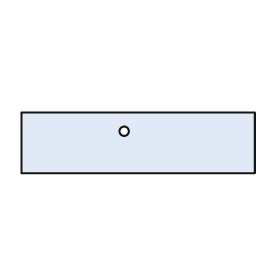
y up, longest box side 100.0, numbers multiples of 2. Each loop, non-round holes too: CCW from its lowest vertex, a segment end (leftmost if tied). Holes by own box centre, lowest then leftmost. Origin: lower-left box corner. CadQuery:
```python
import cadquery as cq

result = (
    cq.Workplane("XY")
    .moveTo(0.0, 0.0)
    .lineTo(100.0, 0.0)
    .lineTo(100.0, 26.0)
    .lineTo(0.0, 26.0)
    .close()
    .moveTo(44.0, 18.0)
    .circle(2.0)
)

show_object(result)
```